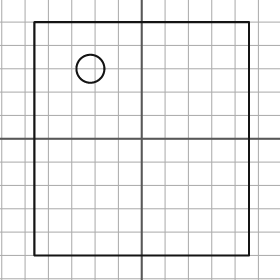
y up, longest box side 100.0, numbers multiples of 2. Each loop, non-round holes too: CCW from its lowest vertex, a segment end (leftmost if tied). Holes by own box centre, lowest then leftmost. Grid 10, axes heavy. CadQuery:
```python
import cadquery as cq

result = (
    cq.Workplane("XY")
    .moveTo(-46.0, -50.0)
    .lineTo(46.0, -50.0)
    .lineTo(46.0, 50.0)
    .lineTo(-46.0, 50.0)
    .close()
    .moveTo(-22.0, 30.0)
    .circle(6.0)
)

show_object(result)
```